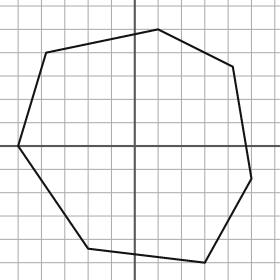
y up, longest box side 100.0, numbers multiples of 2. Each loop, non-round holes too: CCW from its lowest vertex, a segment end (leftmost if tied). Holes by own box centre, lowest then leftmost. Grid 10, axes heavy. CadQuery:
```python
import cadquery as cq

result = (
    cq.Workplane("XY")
    .moveTo(30.0, -50.0)
    .lineTo(50.0, -14.0)
    .lineTo(42.0, 34.0)
    .lineTo(10.0, 50.0)
    .lineTo(-38.0, 40.0)
    .lineTo(-50.0, 0.0)
    .lineTo(-20.0, -44.0)
    .close()
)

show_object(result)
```